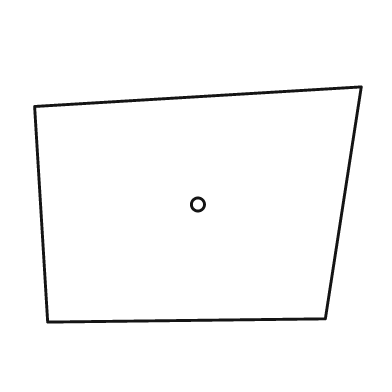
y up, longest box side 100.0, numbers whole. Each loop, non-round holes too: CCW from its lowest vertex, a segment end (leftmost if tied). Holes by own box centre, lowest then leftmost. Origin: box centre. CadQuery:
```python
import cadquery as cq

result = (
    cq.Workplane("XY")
    .moveTo(-46.0, -36.0)
    .lineTo(39.0, -35.0)
    .lineTo(50.0, 36.0)
    .lineTo(-50.0, 30.0)
    .close()
    .moveTo(0.0, 0.0)
    .circle(2.0)
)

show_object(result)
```